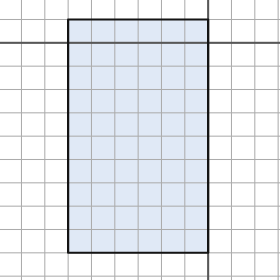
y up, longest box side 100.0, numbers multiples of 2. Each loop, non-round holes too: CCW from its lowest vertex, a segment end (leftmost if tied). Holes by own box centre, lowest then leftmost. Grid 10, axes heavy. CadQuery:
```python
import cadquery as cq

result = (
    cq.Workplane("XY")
    .moveTo(-60.0, -90.0)
    .lineTo(0.0, -90.0)
    .lineTo(0.0, 10.0)
    .lineTo(-60.0, 10.0)
    .close()
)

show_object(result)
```